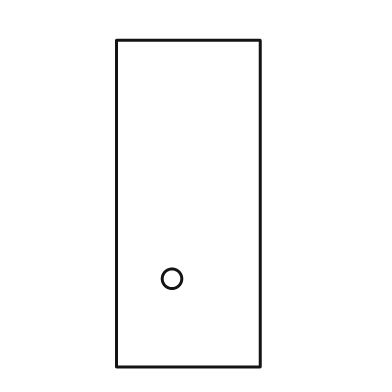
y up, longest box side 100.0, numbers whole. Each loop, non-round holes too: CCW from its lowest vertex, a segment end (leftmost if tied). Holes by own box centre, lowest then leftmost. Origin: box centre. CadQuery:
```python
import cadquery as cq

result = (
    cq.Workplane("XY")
    .moveTo(-22.0, -50.0)
    .lineTo(22.0, -50.0)
    .lineTo(22.0, 50.0)
    .lineTo(-22.0, 50.0)
    .close()
    .moveTo(-5.0, -23.0)
    .circle(3.0)
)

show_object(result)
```